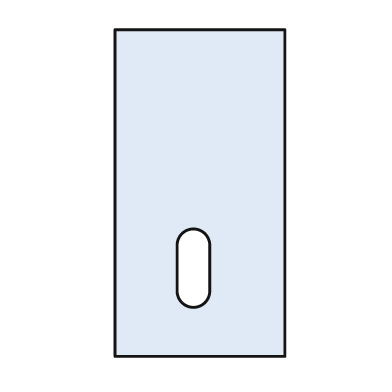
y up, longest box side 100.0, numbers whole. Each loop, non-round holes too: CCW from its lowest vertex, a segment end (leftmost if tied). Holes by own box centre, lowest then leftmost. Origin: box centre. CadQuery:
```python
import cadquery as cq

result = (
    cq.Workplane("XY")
    .moveTo(-26.0, -50.0)
    .lineTo(26.0, -50.0)
    .lineTo(26.0, 50.0)
    .lineTo(-26.0, 50.0)
    .close()
    .moveTo(-7.0, -30.0)
    .threePointArc((-2.0, -35.0), (3.0, -30.0))
    .lineTo(3.0, -16.0)
    .threePointArc((-2.0, -11.0), (-7.0, -16.0))
    .close()
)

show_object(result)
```